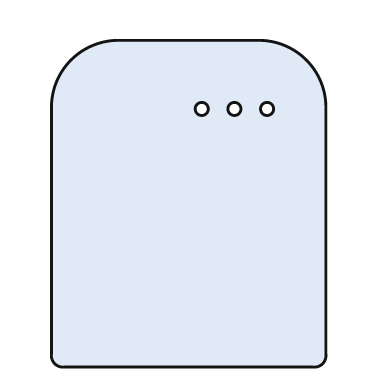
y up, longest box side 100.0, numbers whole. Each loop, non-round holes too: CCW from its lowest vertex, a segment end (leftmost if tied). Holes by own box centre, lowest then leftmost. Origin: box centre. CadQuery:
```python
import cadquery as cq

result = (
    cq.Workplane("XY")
    .moveTo(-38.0, -50.0)
    .lineTo(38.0, -50.0)
    .threePointArc((41.0, -49.0), (42.0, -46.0))
    .lineTo(42.0, 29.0)
    .threePointArc((36.0, 44.0), (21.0, 50.0))
    .lineTo(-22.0, 50.0)
    .threePointArc((-36.0, 44.0), (-42.0, 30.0))
    .lineTo(-42.0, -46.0)
    .threePointArc((-41.0, -49.0), (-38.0, -50.0))
    .close()
    .moveTo(4.0, 29.0)
    .circle(2.0)
    .moveTo(14.0, 29.0)
    .circle(2.0)
    .moveTo(24.0, 29.0)
    .circle(2.0)
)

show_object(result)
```